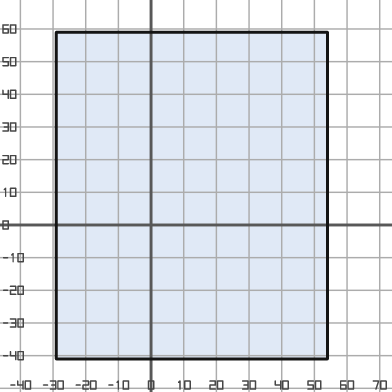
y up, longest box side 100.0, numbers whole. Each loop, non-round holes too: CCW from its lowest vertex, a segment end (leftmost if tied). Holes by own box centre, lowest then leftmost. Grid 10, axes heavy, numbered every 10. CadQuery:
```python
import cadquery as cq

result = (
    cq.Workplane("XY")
    .moveTo(-29.0, -41.0)
    .lineTo(54.0, -41.0)
    .lineTo(54.0, 59.0)
    .lineTo(-29.0, 59.0)
    .close()
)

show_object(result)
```